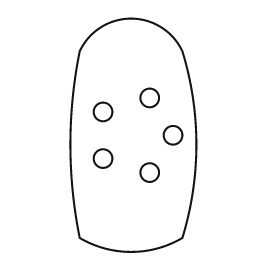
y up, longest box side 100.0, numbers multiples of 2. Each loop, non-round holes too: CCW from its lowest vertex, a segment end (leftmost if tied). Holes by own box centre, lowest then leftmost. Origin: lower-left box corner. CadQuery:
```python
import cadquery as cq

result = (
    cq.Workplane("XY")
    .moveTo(4.0, 6.0)
    .threePointArc((26.0, 0.0), (48.0, 6.0))
    .threePointArc((54.0, 46.0), (48.0, 86.0))
    .threePointArc((26.0, 100.0), (4.0, 86.0))
    .threePointArc((0.0, 46.0), (4.0, 6.0))
    .close()
    .moveTo(34.0, 34.0)
    .circle(4.0)
    .moveTo(14.0, 40.0)
    .circle(4.0)
    .moveTo(44.0, 50.0)
    .circle(4.0)
    .moveTo(14.0, 60.0)
    .circle(4.0)
    .moveTo(34.0, 66.0)
    .circle(4.0)
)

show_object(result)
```